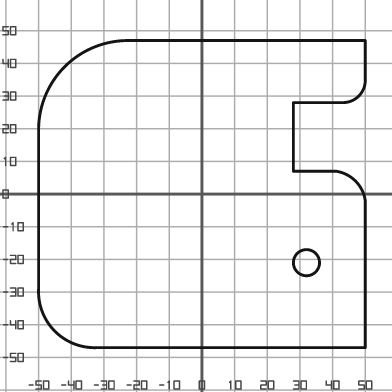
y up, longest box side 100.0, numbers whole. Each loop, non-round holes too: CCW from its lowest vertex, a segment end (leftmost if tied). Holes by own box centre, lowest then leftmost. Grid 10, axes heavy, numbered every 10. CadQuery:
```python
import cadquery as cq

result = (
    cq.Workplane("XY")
    .moveTo(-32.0, -47.0)
    .lineTo(50.0, -47.0)
    .lineTo(50.0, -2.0)
    .threePointArc((47.0, 4.0), (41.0, 7.0))
    .lineTo(28.0, 7.0)
    .lineTo(28.0, 28.0)
    .lineTo(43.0, 28.0)
    .threePointArc((48.0, 30.0), (50.0, 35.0))
    .lineTo(50.0, 47.0)
    .lineTo(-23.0, 47.0)
    .threePointArc((-42.0, 39.0), (-50.0, 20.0))
    .lineTo(-50.0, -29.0)
    .threePointArc((-45.0, -42.0), (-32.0, -47.0))
    .close()
    .moveTo(32.0, -21.0)
    .circle(4.0)
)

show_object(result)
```